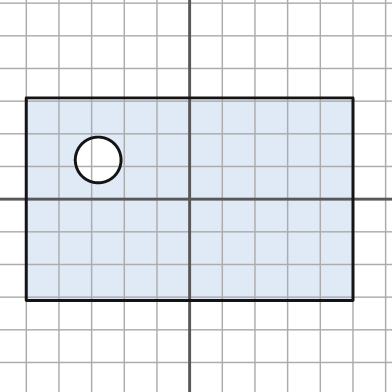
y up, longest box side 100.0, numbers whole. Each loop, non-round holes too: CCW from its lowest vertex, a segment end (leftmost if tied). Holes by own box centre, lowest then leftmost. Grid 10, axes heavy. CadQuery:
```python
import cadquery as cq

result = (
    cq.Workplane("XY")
    .moveTo(-50.0, -31.0)
    .lineTo(50.0, -31.0)
    .lineTo(50.0, 31.0)
    .lineTo(-50.0, 31.0)
    .close()
    .moveTo(-28.0, 12.0)
    .circle(7.0)
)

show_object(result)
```